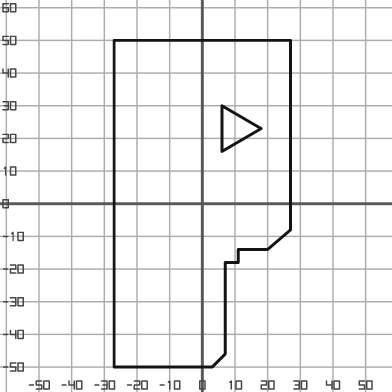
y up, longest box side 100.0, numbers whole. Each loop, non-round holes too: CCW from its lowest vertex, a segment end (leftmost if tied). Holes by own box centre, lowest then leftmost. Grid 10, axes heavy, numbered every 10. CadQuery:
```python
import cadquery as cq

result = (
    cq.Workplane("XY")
    .moveTo(-27.0, -50.0)
    .lineTo(3.0, -50.0)
    .lineTo(7.0, -46.0)
    .lineTo(7.0, -18.0)
    .lineTo(11.0, -18.0)
    .lineTo(11.0, -14.0)
    .lineTo(20.0, -14.0)
    .lineTo(27.0, -8.0)
    .lineTo(27.0, 50.0)
    .lineTo(-27.0, 50.0)
    .close()
    .moveTo(6.0, 16.0)
    .lineTo(18.0, 23.0)
    .lineTo(6.0, 30.0)
    .close()
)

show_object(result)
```